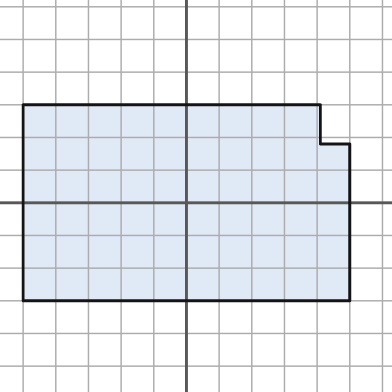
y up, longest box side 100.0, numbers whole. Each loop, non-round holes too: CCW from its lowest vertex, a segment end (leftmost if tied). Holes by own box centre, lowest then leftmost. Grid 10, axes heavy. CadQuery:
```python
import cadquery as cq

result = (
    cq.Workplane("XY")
    .moveTo(-50.0, -30.0)
    .lineTo(50.0, -30.0)
    .lineTo(50.0, 18.0)
    .lineTo(41.0, 18.0)
    .lineTo(41.0, 30.0)
    .lineTo(-50.0, 30.0)
    .close()
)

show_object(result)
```